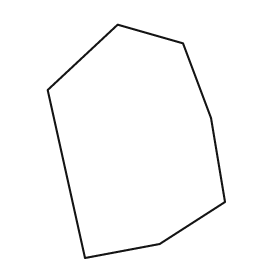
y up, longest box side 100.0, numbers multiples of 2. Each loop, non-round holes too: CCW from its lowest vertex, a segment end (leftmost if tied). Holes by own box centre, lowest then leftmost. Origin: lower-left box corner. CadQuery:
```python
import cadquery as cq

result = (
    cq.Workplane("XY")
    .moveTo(16.0, 0.0)
    .lineTo(48.0, 6.0)
    .lineTo(76.0, 24.0)
    .lineTo(70.0, 60.0)
    .lineTo(58.0, 92.0)
    .lineTo(30.0, 100.0)
    .lineTo(0.0, 72.0)
    .close()
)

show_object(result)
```